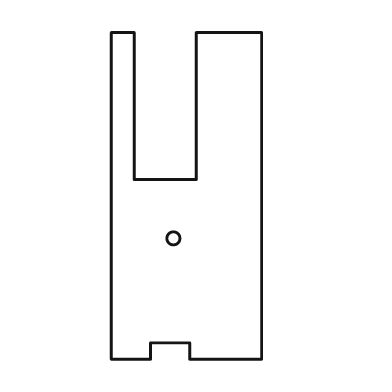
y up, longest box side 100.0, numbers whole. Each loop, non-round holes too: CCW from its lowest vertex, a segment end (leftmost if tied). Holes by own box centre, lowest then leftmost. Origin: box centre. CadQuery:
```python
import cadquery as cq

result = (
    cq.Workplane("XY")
    .moveTo(-23.0, -50.0)
    .lineTo(-11.0, -50.0)
    .lineTo(-11.0, -45.0)
    .lineTo(1.0, -45.0)
    .lineTo(1.0, -50.0)
    .lineTo(23.0, -50.0)
    .lineTo(23.0, 50.0)
    .lineTo(3.0, 50.0)
    .lineTo(3.0, 5.0)
    .lineTo(-16.0, 5.0)
    .lineTo(-16.0, 50.0)
    .lineTo(-23.0, 50.0)
    .close()
    .moveTo(-4.0, -13.0)
    .circle(2.0)
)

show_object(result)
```